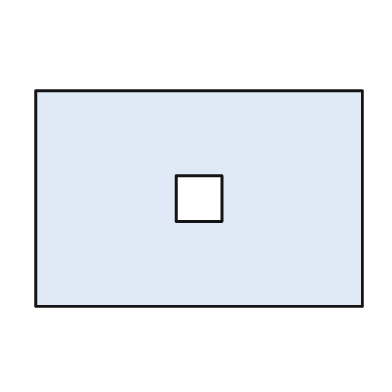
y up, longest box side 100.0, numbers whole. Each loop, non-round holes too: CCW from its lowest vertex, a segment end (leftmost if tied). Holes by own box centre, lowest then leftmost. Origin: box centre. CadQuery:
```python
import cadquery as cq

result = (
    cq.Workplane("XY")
    .moveTo(-50.0, -33.0)
    .lineTo(50.0, -33.0)
    .lineTo(50.0, 33.0)
    .lineTo(-50.0, 33.0)
    .close()
    .moveTo(-7.0, -7.0)
    .lineTo(7.0, -7.0)
    .lineTo(7.0, 7.0)
    .lineTo(-7.0, 7.0)
    .close()
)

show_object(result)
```